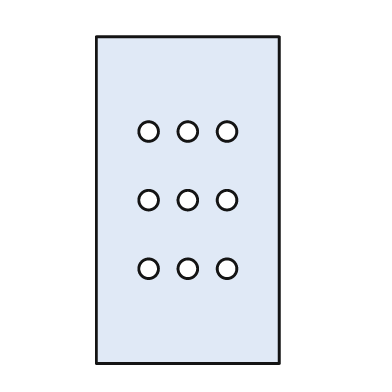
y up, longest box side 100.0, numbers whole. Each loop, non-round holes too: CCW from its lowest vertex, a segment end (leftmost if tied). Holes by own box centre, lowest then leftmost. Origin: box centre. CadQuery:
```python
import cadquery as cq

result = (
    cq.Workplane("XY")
    .moveTo(-28.0, -50.0)
    .lineTo(28.0, -50.0)
    .lineTo(28.0, 50.0)
    .lineTo(-28.0, 50.0)
    .close()
    .moveTo(-12.0, -21.0)
    .circle(3.0)
    .moveTo(0.0, -21.0)
    .circle(3.0)
    .moveTo(12.0, -21.0)
    .circle(3.0)
    .moveTo(-12.0, 0.0)
    .circle(3.0)
    .moveTo(0.0, 0.0)
    .circle(3.0)
    .moveTo(12.0, 0.0)
    .circle(3.0)
    .moveTo(-12.0, 21.0)
    .circle(3.0)
    .moveTo(0.0, 21.0)
    .circle(3.0)
    .moveTo(12.0, 21.0)
    .circle(3.0)
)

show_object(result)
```